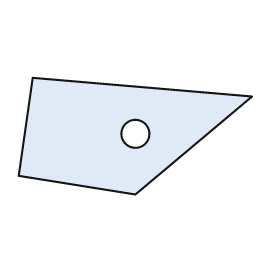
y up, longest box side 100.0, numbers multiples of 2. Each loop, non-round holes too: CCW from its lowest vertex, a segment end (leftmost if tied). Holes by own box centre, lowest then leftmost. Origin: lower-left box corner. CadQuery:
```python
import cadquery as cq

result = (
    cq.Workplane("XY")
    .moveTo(50.0, 0.0)
    .lineTo(100.0, 42.0)
    .lineTo(6.0, 50.0)
    .lineTo(0.0, 8.0)
    .close()
    .moveTo(50.0, 26.0)
    .circle(6.0)
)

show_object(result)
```